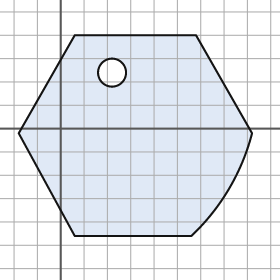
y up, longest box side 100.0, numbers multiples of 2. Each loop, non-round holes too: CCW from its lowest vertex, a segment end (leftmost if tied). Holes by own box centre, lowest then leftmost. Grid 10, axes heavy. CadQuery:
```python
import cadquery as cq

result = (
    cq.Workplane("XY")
    .moveTo(6.0, -46.0)
    .lineTo(56.0, -46.0)
    .threePointArc((72.0, -26.0), (82.0, -2.0))
    .lineTo(58.0, 40.0)
    .lineTo(6.0, 40.0)
    .lineTo(-18.0, -2.0)
    .close()
    .moveTo(22.0, 24.0)
    .circle(6.0)
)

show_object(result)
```